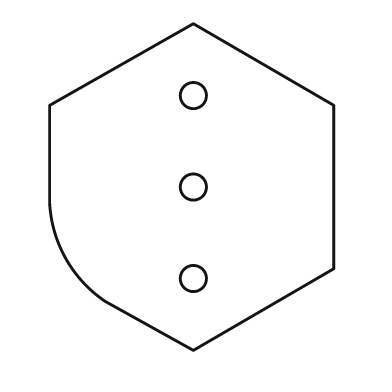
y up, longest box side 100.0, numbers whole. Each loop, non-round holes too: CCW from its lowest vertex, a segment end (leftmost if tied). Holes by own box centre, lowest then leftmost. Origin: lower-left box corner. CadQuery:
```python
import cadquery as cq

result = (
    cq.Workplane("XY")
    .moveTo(44.0, 0.0)
    .lineTo(87.0, 25.0)
    .lineTo(87.0, 75.0)
    .lineTo(44.0, 100.0)
    .lineTo(0.0, 75.0)
    .lineTo(0.0, 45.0)
    .threePointArc((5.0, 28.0), (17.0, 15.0))
    .close()
    .moveTo(44.0, 22.0)
    .circle(4.0)
    .moveTo(44.0, 50.0)
    .circle(4.0)
    .moveTo(44.0, 78.0)
    .circle(4.0)
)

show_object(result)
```